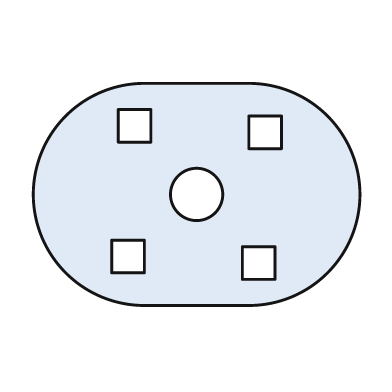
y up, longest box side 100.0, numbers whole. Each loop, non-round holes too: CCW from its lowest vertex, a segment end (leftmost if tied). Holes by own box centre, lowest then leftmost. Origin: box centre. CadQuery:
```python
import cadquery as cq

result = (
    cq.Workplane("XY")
    .moveTo(-16.0, -34.0)
    .lineTo(16.0, -34.0)
    .threePointArc((50.0, 0.0), (16.0, 34.0))
    .lineTo(-16.0, 34.0)
    .threePointArc((-50.0, 0.0), (-16.0, -34.0))
    .close()
    .moveTo(14.0, -26.0)
    .lineTo(24.0, -26.0)
    .lineTo(24.0, -16.0)
    .lineTo(14.0, -16.0)
    .close()
    .moveTo(-26.0, -24.0)
    .lineTo(-16.0, -24.0)
    .lineTo(-16.0, -14.0)
    .lineTo(-26.0, -14.0)
    .close()
    .moveTo(0.0, 0.0)
    .circle(8.0)
    .moveTo(16.0, 14.0)
    .lineTo(26.0, 14.0)
    .lineTo(26.0, 24.0)
    .lineTo(16.0, 24.0)
    .close()
    .moveTo(-24.0, 16.0)
    .lineTo(-14.0, 16.0)
    .lineTo(-14.0, 26.0)
    .lineTo(-24.0, 26.0)
    .close()
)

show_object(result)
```